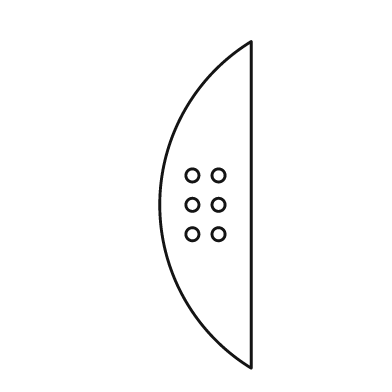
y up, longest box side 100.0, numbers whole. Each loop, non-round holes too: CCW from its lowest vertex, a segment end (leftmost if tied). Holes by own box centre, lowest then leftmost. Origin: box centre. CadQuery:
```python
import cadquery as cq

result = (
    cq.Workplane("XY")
    .moveTo(14.0, -50.0)
    .lineTo(14.0, 50.0)
    .threePointArc((-14.0, 0.0), (14.0, -50.0))
    .close()
    .moveTo(-4.0, -9.0)
    .circle(2.0)
    .moveTo(4.0, -9.0)
    .circle(2.0)
    .moveTo(-4.0, 0.0)
    .circle(2.0)
    .moveTo(4.0, 0.0)
    .circle(2.0)
    .moveTo(-4.0, 9.0)
    .circle(2.0)
    .moveTo(4.0, 9.0)
    .circle(2.0)
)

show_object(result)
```